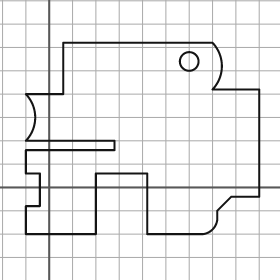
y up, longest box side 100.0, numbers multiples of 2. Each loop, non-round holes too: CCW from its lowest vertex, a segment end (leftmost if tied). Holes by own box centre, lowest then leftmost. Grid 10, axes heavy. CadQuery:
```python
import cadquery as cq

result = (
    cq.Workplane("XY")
    .moveTo(-10.0, -20.0)
    .lineTo(20.0, -20.0)
    .lineTo(20.0, 6.0)
    .lineTo(42.0, 6.0)
    .lineTo(42.0, -20.0)
    .lineTo(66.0, -20.0)
    .threePointArc((70.0, -18.0), (72.0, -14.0))
    .lineTo(72.0, -10.0)
    .lineTo(78.0, -4.0)
    .lineTo(90.0, -4.0)
    .lineTo(90.0, 42.0)
    .lineTo(70.0, 42.0)
    .threePointArc((74.0, 52.0), (70.0, 62.0))
    .lineTo(6.0, 62.0)
    .lineTo(6.0, 40.0)
    .lineTo(-10.0, 40.0)
    .threePointArc((-6.0, 30.0), (-10.0, 20.0))
    .lineTo(28.0, 20.0)
    .lineTo(28.0, 16.0)
    .lineTo(-10.0, 16.0)
    .lineTo(-10.0, 6.0)
    .lineTo(-4.0, 6.0)
    .lineTo(-4.0, -8.0)
    .lineTo(-10.0, -8.0)
    .close()
    .moveTo(60.0, 54.0)
    .circle(4.0)
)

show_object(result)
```